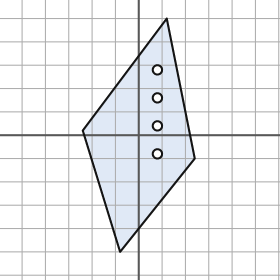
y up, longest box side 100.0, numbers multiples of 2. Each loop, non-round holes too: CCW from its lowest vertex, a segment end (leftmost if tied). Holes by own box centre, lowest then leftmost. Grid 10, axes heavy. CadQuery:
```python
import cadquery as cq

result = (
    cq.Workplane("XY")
    .moveTo(-8.0, -50.0)
    .lineTo(24.0, -10.0)
    .lineTo(12.0, 50.0)
    .lineTo(-24.0, 2.0)
    .close()
    .moveTo(8.0, -8.0)
    .circle(2.0)
    .moveTo(8.0, 4.0)
    .circle(2.0)
    .moveTo(8.0, 16.0)
    .circle(2.0)
    .moveTo(8.0, 28.0)
    .circle(2.0)
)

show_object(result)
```